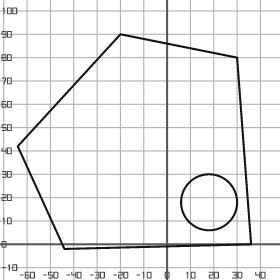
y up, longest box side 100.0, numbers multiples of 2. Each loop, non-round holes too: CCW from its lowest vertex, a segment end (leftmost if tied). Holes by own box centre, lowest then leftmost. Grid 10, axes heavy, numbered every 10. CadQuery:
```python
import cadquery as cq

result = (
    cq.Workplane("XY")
    .moveTo(-44.0, -2.0)
    .lineTo(36.0, 0.0)
    .lineTo(30.0, 80.0)
    .lineTo(-20.0, 90.0)
    .lineTo(-64.0, 42.0)
    .close()
    .moveTo(18.0, 18.0)
    .circle(12.0)
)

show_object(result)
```